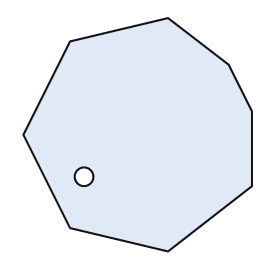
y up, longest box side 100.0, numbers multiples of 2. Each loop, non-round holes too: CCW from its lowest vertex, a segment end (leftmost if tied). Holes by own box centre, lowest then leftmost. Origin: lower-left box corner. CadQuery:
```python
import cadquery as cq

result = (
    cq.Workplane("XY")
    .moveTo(62.0, 0.0)
    .lineTo(98.0, 28.0)
    .lineTo(98.0, 60.0)
    .lineTo(88.0, 80.0)
    .lineTo(62.0, 100.0)
    .lineTo(20.0, 90.0)
    .lineTo(0.0, 50.0)
    .lineTo(20.0, 10.0)
    .close()
    .moveTo(26.0, 32.0)
    .circle(4.0)
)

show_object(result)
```